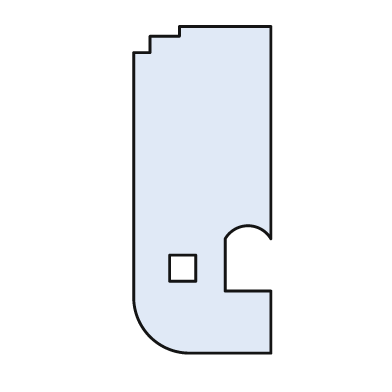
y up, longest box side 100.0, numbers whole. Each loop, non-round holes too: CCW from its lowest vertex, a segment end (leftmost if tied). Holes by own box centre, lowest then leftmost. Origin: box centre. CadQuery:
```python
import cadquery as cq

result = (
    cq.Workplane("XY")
    .moveTo(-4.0, -50.0)
    .lineTo(21.0, -50.0)
    .lineTo(21.0, -31.0)
    .lineTo(7.0, -31.0)
    .lineTo(7.0, -15.0)
    .threePointArc((14.0, -11.0), (21.0, -15.0))
    .lineTo(21.0, 50.0)
    .lineTo(-7.0, 50.0)
    .lineTo(-7.0, 47.0)
    .lineTo(-16.0, 47.0)
    .lineTo(-16.0, 42.0)
    .lineTo(-21.0, 42.0)
    .lineTo(-21.0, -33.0)
    .threePointArc((-16.0, -45.0), (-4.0, -50.0))
    .close()
    .moveTo(-10.0, -28.0)
    .lineTo(-2.0, -28.0)
    .lineTo(-2.0, -20.0)
    .lineTo(-10.0, -20.0)
    .close()
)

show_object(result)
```